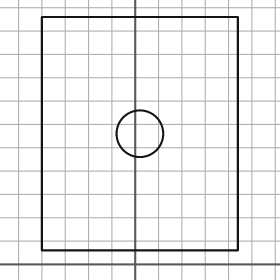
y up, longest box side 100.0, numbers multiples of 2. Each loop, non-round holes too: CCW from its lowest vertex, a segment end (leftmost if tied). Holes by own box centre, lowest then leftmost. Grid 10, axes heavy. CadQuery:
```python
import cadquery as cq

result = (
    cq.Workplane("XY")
    .moveTo(-40.0, 6.0)
    .lineTo(44.0, 6.0)
    .lineTo(44.0, 106.0)
    .lineTo(-40.0, 106.0)
    .close()
    .moveTo(2.0, 56.0)
    .circle(10.0)
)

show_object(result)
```